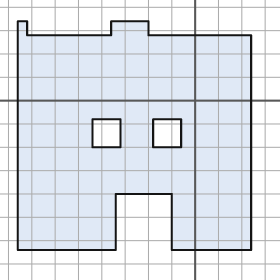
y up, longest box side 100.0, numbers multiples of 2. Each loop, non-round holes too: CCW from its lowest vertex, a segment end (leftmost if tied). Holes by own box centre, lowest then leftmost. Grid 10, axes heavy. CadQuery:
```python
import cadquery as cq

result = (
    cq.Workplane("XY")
    .moveTo(-76.0, -64.0)
    .lineTo(-34.0, -64.0)
    .lineTo(-34.0, -40.0)
    .lineTo(-10.0, -40.0)
    .lineTo(-10.0, -64.0)
    .lineTo(24.0, -64.0)
    .lineTo(24.0, 28.0)
    .lineTo(-20.0, 28.0)
    .lineTo(-20.0, 34.0)
    .lineTo(-36.0, 34.0)
    .lineTo(-36.0, 28.0)
    .lineTo(-72.0, 28.0)
    .lineTo(-72.0, 34.0)
    .lineTo(-76.0, 34.0)
    .close()
    .moveTo(-44.0, -20.0)
    .lineTo(-32.0, -20.0)
    .lineTo(-32.0, -8.0)
    .lineTo(-44.0, -8.0)
    .close()
    .moveTo(-18.0, -20.0)
    .lineTo(-6.0, -20.0)
    .lineTo(-6.0, -8.0)
    .lineTo(-18.0, -8.0)
    .close()
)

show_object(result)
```